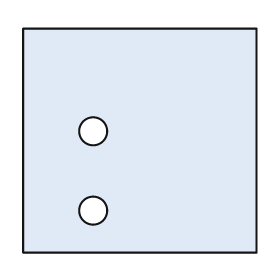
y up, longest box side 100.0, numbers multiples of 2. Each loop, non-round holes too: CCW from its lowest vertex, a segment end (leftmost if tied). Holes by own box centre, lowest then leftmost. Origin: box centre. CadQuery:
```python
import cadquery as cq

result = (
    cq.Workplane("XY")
    .moveTo(-50.0, -48.0)
    .lineTo(50.0, -48.0)
    .lineTo(50.0, 48.0)
    .lineTo(-50.0, 48.0)
    .close()
    .moveTo(-20.0, -30.0)
    .circle(6.0)
    .moveTo(-20.0, 4.0)
    .circle(6.0)
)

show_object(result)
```